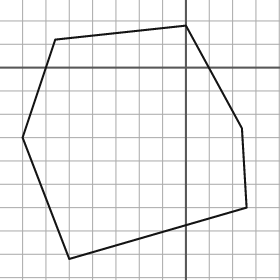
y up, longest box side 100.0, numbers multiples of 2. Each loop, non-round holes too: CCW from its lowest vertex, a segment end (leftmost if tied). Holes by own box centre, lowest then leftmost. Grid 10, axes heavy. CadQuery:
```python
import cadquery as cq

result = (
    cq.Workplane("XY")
    .moveTo(-50.0, -82.0)
    .lineTo(26.0, -60.0)
    .lineTo(24.0, -26.0)
    .lineTo(0.0, 18.0)
    .lineTo(-56.0, 12.0)
    .lineTo(-70.0, -30.0)
    .close()
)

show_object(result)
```